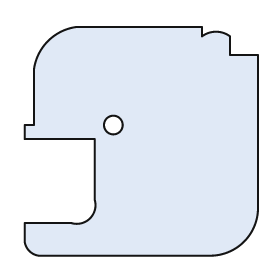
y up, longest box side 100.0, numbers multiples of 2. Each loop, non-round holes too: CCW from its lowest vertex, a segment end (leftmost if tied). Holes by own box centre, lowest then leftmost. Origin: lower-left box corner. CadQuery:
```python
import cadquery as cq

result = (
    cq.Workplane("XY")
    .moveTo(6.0, 0.0)
    .lineTo(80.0, 0.0)
    .threePointArc((94.0, 6.0), (100.0, 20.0))
    .lineTo(100.0, 86.0)
    .lineTo(88.0, 86.0)
    .lineTo(88.0, 94.0)
    .threePointArc((82.0, 96.0), (76.0, 94.0))
    .lineTo(76.0, 98.0)
    .lineTo(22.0, 98.0)
    .threePointArc((10.0, 92.0), (4.0, 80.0))
    .lineTo(4.0, 56.0)
    .lineTo(0.0, 56.0)
    .lineTo(0.0, 50.0)
    .lineTo(30.0, 50.0)
    .lineTo(30.0, 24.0)
    .threePointArc((28.0, 16.0), (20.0, 14.0))
    .lineTo(0.0, 14.0)
    .lineTo(0.0, 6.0)
    .threePointArc((2.0, 2.0), (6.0, 0.0))
    .close()
    .moveTo(38.0, 56.0)
    .circle(4.0)
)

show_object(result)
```